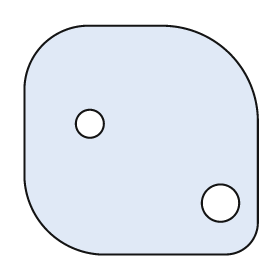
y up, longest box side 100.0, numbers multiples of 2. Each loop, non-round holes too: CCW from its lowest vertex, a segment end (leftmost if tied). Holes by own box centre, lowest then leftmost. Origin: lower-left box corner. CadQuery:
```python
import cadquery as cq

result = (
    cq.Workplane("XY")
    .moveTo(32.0, 0.0)
    .lineTo(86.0, 0.0)
    .threePointArc((96.0, 4.0), (100.0, 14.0))
    .lineTo(100.0, 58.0)
    .threePointArc((88.0, 86.0), (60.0, 98.0))
    .lineTo(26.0, 98.0)
    .threePointArc((8.0, 90.0), (0.0, 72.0))
    .lineTo(0.0, 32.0)
    .threePointArc((10.0, 10.0), (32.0, 0.0))
    .close()
    .moveTo(84.0, 22.0)
    .circle(8.0)
    .moveTo(28.0, 56.0)
    .circle(6.0)
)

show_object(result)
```